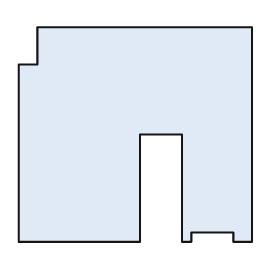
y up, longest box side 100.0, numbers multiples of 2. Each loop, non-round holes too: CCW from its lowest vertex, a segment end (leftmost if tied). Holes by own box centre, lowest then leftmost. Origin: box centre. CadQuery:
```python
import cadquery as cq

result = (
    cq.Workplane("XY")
    .moveTo(-50.0, -46.0)
    .lineTo(2.0, -46.0)
    .lineTo(2.0, 0.0)
    .lineTo(20.0, 0.0)
    .lineTo(20.0, -46.0)
    .lineTo(24.0, -46.0)
    .lineTo(24.0, -42.0)
    .lineTo(42.0, -42.0)
    .lineTo(42.0, -46.0)
    .lineTo(50.0, -46.0)
    .lineTo(50.0, 46.0)
    .lineTo(-42.0, 46.0)
    .lineTo(-42.0, 30.0)
    .lineTo(-50.0, 30.0)
    .close()
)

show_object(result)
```